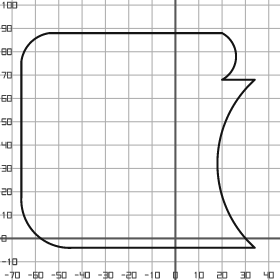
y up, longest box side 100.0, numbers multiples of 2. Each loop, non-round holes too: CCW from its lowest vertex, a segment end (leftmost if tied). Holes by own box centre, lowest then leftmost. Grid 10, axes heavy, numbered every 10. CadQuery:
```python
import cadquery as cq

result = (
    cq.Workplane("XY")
    .moveTo(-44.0, -4.0)
    .lineTo(34.0, -4.0)
    .threePointArc((18.0, 32.0), (34.0, 68.0))
    .lineTo(20.0, 68.0)
    .threePointArc((26.0, 78.0), (20.0, 88.0))
    .lineTo(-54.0, 88.0)
    .threePointArc((-62.0, 84.0), (-66.0, 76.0))
    .lineTo(-66.0, 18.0)
    .threePointArc((-60.0, 2.0), (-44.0, -4.0))
    .close()
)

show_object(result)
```